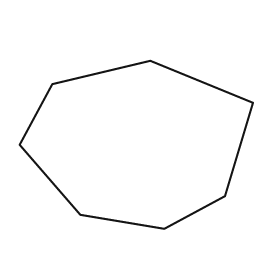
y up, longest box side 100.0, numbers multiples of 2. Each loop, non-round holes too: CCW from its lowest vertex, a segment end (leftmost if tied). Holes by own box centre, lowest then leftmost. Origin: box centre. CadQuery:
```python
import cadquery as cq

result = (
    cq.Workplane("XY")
    .moveTo(12.0, -36.0)
    .lineTo(38.0, -22.0)
    .lineTo(50.0, 18.0)
    .lineTo(6.0, 36.0)
    .lineTo(-36.0, 26.0)
    .lineTo(-50.0, 0.0)
    .lineTo(-24.0, -30.0)
    .close()
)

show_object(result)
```